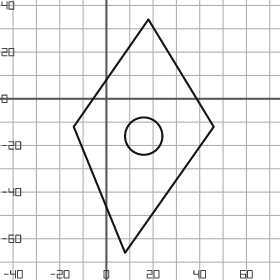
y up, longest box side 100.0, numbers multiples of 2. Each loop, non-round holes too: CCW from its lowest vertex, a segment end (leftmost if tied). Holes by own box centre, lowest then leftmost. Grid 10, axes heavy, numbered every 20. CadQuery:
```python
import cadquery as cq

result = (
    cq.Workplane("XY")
    .moveTo(8.0, -66.0)
    .lineTo(46.0, -12.0)
    .lineTo(18.0, 34.0)
    .lineTo(-14.0, -12.0)
    .close()
    .moveTo(16.0, -16.0)
    .circle(8.0)
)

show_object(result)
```